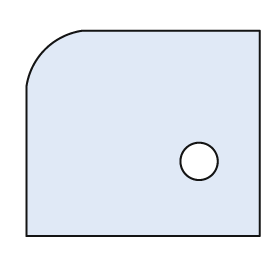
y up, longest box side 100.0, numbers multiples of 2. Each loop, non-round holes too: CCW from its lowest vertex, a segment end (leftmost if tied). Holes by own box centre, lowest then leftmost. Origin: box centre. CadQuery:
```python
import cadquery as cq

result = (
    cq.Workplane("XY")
    .moveTo(-50.0, -44.0)
    .lineTo(50.0, -44.0)
    .lineTo(50.0, 44.0)
    .lineTo(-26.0, 44.0)
    .threePointArc((-42.0, 36.0), (-50.0, 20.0))
    .close()
    .moveTo(24.0, -12.0)
    .circle(8.0)
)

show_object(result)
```